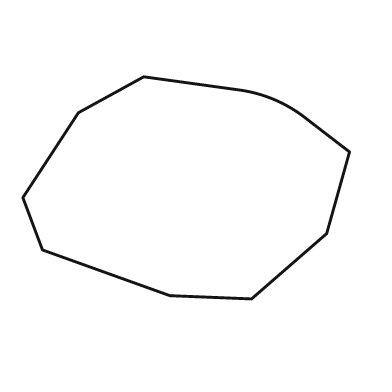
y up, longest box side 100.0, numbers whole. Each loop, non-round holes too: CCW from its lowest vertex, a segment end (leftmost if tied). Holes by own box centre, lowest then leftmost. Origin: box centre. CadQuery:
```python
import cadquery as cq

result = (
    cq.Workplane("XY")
    .moveTo(20.0, -34.0)
    .lineTo(43.0, -14.0)
    .lineTo(50.0, 11.0)
    .lineTo(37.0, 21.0)
    .threePointArc((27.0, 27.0), (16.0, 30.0))
    .lineTo(-13.0, 34.0)
    .lineTo(-33.0, 23.0)
    .lineTo(-50.0, -3.0)
    .lineTo(-44.0, -19.0)
    .lineTo(-5.0, -33.0)
    .close()
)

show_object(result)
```